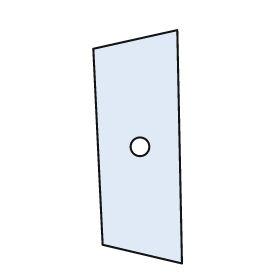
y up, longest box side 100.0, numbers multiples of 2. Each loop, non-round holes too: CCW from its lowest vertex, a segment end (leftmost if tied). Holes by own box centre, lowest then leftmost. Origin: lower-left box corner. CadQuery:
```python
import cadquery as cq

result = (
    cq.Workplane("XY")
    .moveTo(38.0, 0.0)
    .lineTo(36.0, 100.0)
    .lineTo(0.0, 92.0)
    .lineTo(4.0, 8.0)
    .close()
    .moveTo(20.0, 50.0)
    .circle(4.0)
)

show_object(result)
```